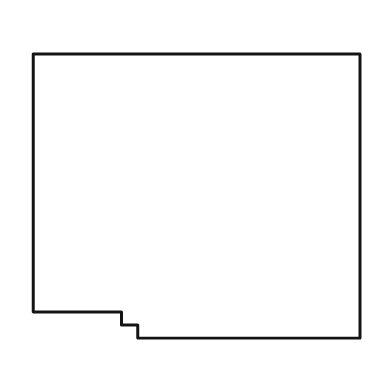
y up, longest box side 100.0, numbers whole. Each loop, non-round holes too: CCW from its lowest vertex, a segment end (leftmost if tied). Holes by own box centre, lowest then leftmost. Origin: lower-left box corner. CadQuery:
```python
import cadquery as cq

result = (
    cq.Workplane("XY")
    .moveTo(32.0, 0.0)
    .lineTo(100.0, 0.0)
    .lineTo(100.0, 87.0)
    .lineTo(0.0, 87.0)
    .lineTo(0.0, 8.0)
    .lineTo(27.0, 8.0)
    .lineTo(27.0, 4.0)
    .lineTo(32.0, 4.0)
    .close()
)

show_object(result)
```